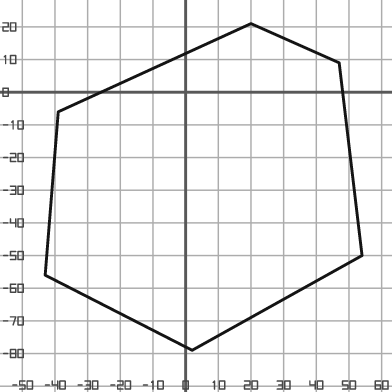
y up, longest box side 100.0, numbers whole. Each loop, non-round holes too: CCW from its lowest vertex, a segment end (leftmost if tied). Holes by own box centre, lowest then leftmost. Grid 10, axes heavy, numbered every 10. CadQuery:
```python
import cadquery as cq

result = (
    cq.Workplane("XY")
    .moveTo(2.0, -79.0)
    .lineTo(54.0, -50.0)
    .lineTo(47.0, 9.0)
    .lineTo(20.0, 21.0)
    .lineTo(-39.0, -6.0)
    .lineTo(-43.0, -56.0)
    .close()
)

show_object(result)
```